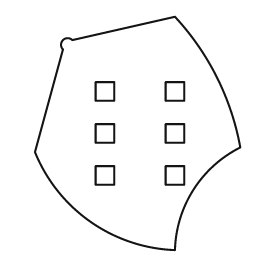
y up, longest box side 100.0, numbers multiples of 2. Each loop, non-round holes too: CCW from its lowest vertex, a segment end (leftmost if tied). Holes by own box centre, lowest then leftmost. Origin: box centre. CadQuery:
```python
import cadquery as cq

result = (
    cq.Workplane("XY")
    .moveTo(16.0, -50.0)
    .threePointArc((24.0, -24.0), (44.0, -6.0))
    .threePointArc((34.0, 24.0), (16.0, 50.0))
    .lineTo(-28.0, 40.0)
    .threePointArc((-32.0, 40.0), (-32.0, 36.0))
    .lineTo(-44.0, -8.0)
    .threePointArc((-20.0, -38.0), (16.0, -50.0))
    .close()
    .moveTo(-18.0, -22.0)
    .lineTo(-10.0, -22.0)
    .lineTo(-10.0, -14.0)
    .lineTo(-18.0, -14.0)
    .close()
    .moveTo(12.0, -22.0)
    .lineTo(20.0, -22.0)
    .lineTo(20.0, -14.0)
    .lineTo(12.0, -14.0)
    .close()
    .moveTo(-18.0, -4.0)
    .lineTo(-10.0, -4.0)
    .lineTo(-10.0, 4.0)
    .lineTo(-18.0, 4.0)
    .close()
    .moveTo(12.0, -4.0)
    .lineTo(20.0, -4.0)
    .lineTo(20.0, 4.0)
    .lineTo(12.0, 4.0)
    .close()
    .moveTo(-18.0, 14.0)
    .lineTo(-10.0, 14.0)
    .lineTo(-10.0, 22.0)
    .lineTo(-18.0, 22.0)
    .close()
    .moveTo(12.0, 14.0)
    .lineTo(20.0, 14.0)
    .lineTo(20.0, 22.0)
    .lineTo(12.0, 22.0)
    .close()
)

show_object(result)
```